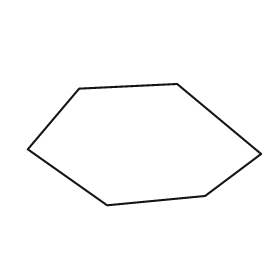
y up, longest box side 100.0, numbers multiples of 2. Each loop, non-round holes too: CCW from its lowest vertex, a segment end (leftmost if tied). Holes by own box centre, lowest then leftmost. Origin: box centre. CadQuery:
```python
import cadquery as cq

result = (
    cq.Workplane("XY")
    .moveTo(-16.0, -26.0)
    .lineTo(26.0, -22.0)
    .lineTo(50.0, -4.0)
    .lineTo(14.0, 26.0)
    .lineTo(-28.0, 24.0)
    .lineTo(-50.0, -2.0)
    .close()
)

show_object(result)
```